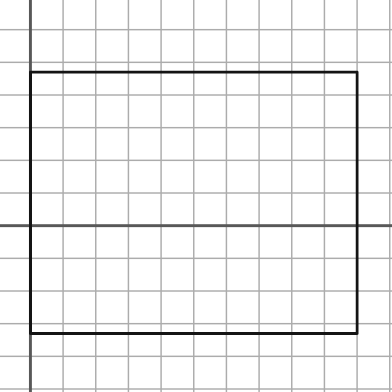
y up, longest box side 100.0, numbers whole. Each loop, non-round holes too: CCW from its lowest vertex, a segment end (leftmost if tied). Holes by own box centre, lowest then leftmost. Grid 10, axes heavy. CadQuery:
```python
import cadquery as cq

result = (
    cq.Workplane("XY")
    .moveTo(0.0, -33.0)
    .lineTo(100.0, -33.0)
    .lineTo(100.0, 47.0)
    .lineTo(0.0, 47.0)
    .close()
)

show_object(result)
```